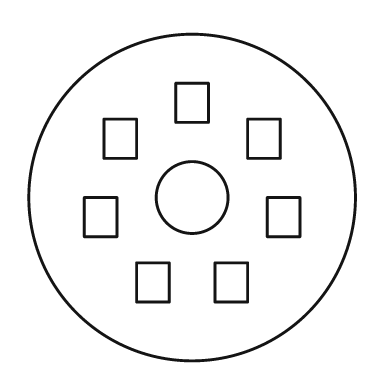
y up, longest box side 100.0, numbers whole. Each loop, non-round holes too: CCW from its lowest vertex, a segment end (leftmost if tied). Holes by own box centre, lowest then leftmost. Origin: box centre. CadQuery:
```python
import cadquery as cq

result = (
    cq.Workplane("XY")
    .moveTo(0.0, 0.0)
    .circle(50.0)
    .moveTo(-17.0, -32.0)
    .lineTo(-7.0, -32.0)
    .lineTo(-7.0, -20.0)
    .lineTo(-17.0, -20.0)
    .close()
    .moveTo(7.0, -32.0)
    .lineTo(17.0, -32.0)
    .lineTo(17.0, -20.0)
    .lineTo(7.0, -20.0)
    .close()
    .moveTo(-33.0, -12.0)
    .lineTo(-23.0, -12.0)
    .lineTo(-23.0, 0.0)
    .lineTo(-33.0, 0.0)
    .close()
    .moveTo(23.0, -12.0)
    .lineTo(33.0, -12.0)
    .lineTo(33.0, 0.0)
    .lineTo(23.0, 0.0)
    .close()
    .moveTo(0.0, 0.0)
    .circle(11.0)
    .moveTo(-27.0, 12.0)
    .lineTo(-17.0, 12.0)
    .lineTo(-17.0, 24.0)
    .lineTo(-27.0, 24.0)
    .close()
    .moveTo(17.0, 12.0)
    .lineTo(27.0, 12.0)
    .lineTo(27.0, 24.0)
    .lineTo(17.0, 24.0)
    .close()
    .moveTo(-5.0, 23.0)
    .lineTo(5.0, 23.0)
    .lineTo(5.0, 35.0)
    .lineTo(-5.0, 35.0)
    .close()
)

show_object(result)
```